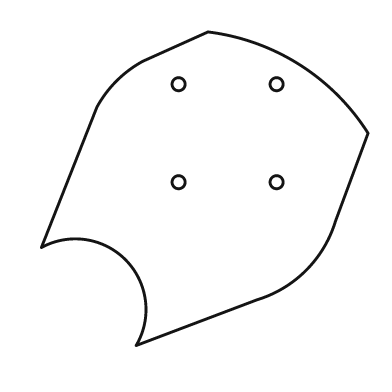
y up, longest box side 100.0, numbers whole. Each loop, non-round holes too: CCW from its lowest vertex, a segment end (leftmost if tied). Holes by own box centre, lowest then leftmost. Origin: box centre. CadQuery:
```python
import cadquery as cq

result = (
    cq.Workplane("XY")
    .moveTo(-21.0, -48.0)
    .lineTo(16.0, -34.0)
    .threePointArc((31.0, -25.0), (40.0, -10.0))
    .lineTo(50.0, 17.0)
    .threePointArc((29.0, 38.0), (1.0, 48.0))
    .lineTo(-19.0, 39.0)
    .threePointArc((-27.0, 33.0), (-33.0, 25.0))
    .lineTo(-50.0, -18.0)
    .threePointArc((-24.0, -22.0), (-21.0, -48.0))
    .close()
    .moveTo(-8.0, 2.0)
    .circle(2.0)
    .moveTo(22.0, 2.0)
    .circle(2.0)
    .moveTo(-8.0, 32.0)
    .circle(2.0)
    .moveTo(22.0, 32.0)
    .circle(2.0)
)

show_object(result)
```